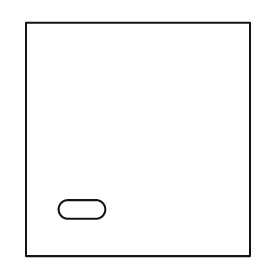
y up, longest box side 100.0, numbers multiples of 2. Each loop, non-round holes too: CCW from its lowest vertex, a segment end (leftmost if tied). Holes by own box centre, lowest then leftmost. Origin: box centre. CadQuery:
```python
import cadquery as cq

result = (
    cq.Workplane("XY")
    .moveTo(-48.0, -50.0)
    .lineTo(48.0, -50.0)
    .lineTo(48.0, 50.0)
    .lineTo(-48.0, 50.0)
    .close()
    .moveTo(-30.0, -34.0)
    .lineTo(-18.0, -34.0)
    .threePointArc((-14.0, -30.0), (-18.0, -26.0))
    .lineTo(-30.0, -26.0)
    .threePointArc((-34.0, -30.0), (-30.0, -34.0))
    .close()
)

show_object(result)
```